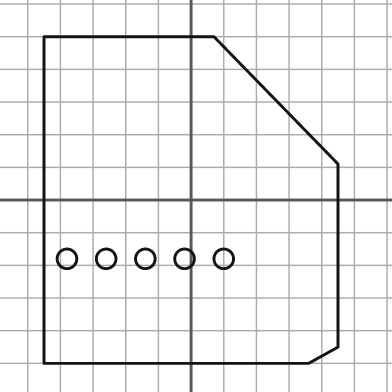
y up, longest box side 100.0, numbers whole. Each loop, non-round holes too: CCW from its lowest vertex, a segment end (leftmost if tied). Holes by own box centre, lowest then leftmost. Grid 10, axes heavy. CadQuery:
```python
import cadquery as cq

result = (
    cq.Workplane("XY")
    .moveTo(-45.0, -50.0)
    .lineTo(36.0, -50.0)
    .lineTo(45.0, -45.0)
    .lineTo(45.0, 11.0)
    .lineTo(7.0, 50.0)
    .lineTo(-45.0, 50.0)
    .close()
    .moveTo(-38.0, -18.0)
    .circle(3.0)
    .moveTo(-26.0, -18.0)
    .circle(3.0)
    .moveTo(-14.0, -18.0)
    .circle(3.0)
    .moveTo(-2.0, -18.0)
    .circle(3.0)
    .moveTo(10.0, -18.0)
    .circle(3.0)
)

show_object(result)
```